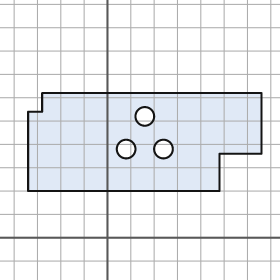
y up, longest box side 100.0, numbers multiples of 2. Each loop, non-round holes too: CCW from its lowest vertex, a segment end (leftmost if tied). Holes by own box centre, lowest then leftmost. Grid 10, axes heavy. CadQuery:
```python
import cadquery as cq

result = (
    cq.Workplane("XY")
    .moveTo(-34.0, 20.0)
    .lineTo(48.0, 20.0)
    .lineTo(48.0, 36.0)
    .lineTo(66.0, 36.0)
    .lineTo(66.0, 62.0)
    .lineTo(-28.0, 62.0)
    .lineTo(-28.0, 54.0)
    .lineTo(-34.0, 54.0)
    .close()
    .moveTo(8.0, 38.0)
    .circle(4.0)
    .moveTo(24.0, 38.0)
    .circle(4.0)
    .moveTo(16.0, 52.0)
    .circle(4.0)
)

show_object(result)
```